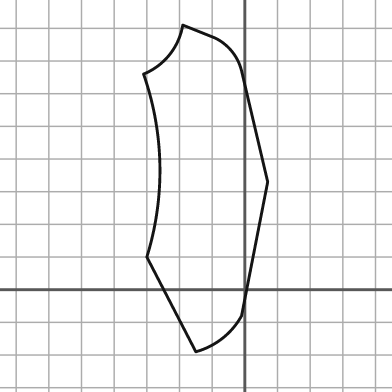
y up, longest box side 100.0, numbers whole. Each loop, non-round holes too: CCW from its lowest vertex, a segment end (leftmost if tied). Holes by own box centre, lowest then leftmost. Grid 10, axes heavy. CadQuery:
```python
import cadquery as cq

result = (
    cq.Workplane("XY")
    .moveTo(-15.0, -19.0)
    .threePointArc((-7.0, -15.0), (-1.0, -8.0))
    .lineTo(7.0, 33.0)
    .lineTo(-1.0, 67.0)
    .threePointArc((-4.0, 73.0), (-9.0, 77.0))
    .lineTo(-19.0, 81.0)
    .threePointArc((-23.0, 72.0), (-31.0, 66.0))
    .threePointArc((-26.0, 38.0), (-30.0, 10.0))
    .close()
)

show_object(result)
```